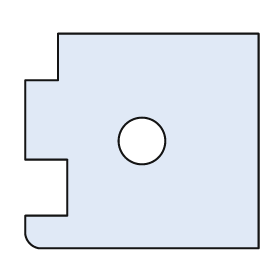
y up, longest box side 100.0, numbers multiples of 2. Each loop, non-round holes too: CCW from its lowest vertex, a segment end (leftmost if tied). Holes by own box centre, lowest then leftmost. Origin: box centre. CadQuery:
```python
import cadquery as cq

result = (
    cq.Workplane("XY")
    .moveTo(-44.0, -46.0)
    .lineTo(50.0, -46.0)
    .lineTo(50.0, 46.0)
    .lineTo(-36.0, 46.0)
    .lineTo(-36.0, 26.0)
    .lineTo(-50.0, 26.0)
    .lineTo(-50.0, -8.0)
    .lineTo(-32.0, -8.0)
    .lineTo(-32.0, -32.0)
    .lineTo(-50.0, -32.0)
    .lineTo(-50.0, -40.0)
    .threePointArc((-48.0, -44.0), (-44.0, -46.0))
    .close()
    .moveTo(0.0, 0.0)
    .circle(10.0)
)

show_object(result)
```